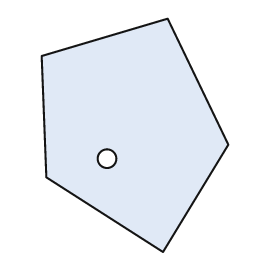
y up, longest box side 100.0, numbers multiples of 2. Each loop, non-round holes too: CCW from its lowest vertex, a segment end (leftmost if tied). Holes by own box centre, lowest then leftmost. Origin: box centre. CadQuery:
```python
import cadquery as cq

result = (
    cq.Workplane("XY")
    .moveTo(12.0, -50.0)
    .lineTo(40.0, -4.0)
    .lineTo(14.0, 50.0)
    .lineTo(-40.0, 34.0)
    .lineTo(-38.0, -18.0)
    .close()
    .moveTo(-12.0, -10.0)
    .circle(4.0)
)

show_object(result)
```